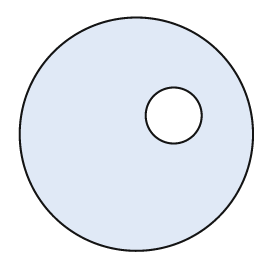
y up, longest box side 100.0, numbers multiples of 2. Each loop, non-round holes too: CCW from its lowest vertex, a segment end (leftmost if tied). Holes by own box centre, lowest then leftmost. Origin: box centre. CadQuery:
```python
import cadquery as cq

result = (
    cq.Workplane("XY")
    .moveTo(0.0, 0.0)
    .circle(50.0)
    .moveTo(16.0, 8.0)
    .circle(12.0)
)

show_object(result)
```